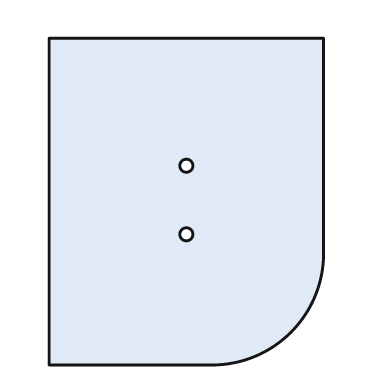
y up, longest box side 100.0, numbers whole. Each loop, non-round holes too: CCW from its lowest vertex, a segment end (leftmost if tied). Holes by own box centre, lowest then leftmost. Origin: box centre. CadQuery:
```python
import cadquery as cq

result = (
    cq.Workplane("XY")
    .moveTo(-42.0, -50.0)
    .lineTo(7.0, -50.0)
    .threePointArc((32.0, -40.0), (42.0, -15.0))
    .lineTo(42.0, 50.0)
    .lineTo(-42.0, 50.0)
    .close()
    .moveTo(0.0, -10.0)
    .circle(2.0)
    .moveTo(0.0, 11.0)
    .circle(2.0)
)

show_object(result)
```